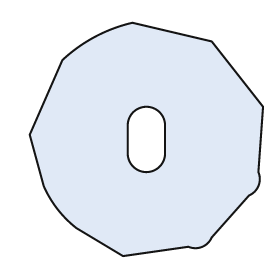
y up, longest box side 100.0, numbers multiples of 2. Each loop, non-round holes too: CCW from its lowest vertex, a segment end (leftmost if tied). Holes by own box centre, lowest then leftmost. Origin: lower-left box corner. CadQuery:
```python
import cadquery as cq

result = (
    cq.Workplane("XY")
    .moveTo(40.0, 0.0)
    .lineTo(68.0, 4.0)
    .threePointArc((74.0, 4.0), (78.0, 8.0))
    .lineTo(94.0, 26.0)
    .threePointArc((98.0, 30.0), (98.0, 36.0))
    .lineTo(100.0, 64.0)
    .lineTo(78.0, 92.0)
    .lineTo(44.0, 100.0)
    .threePointArc((28.0, 94.0), (14.0, 84.0))
    .lineTo(0.0, 52.0)
    .lineTo(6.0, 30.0)
    .threePointArc((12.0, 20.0), (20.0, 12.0))
    .close()
    .moveTo(42.0, 44.0)
    .threePointArc((50.0, 36.0), (58.0, 44.0))
    .lineTo(58.0, 56.0)
    .threePointArc((50.0, 64.0), (42.0, 56.0))
    .close()
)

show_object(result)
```